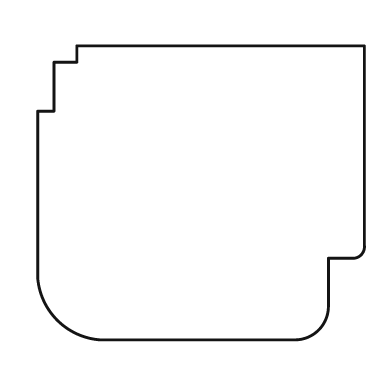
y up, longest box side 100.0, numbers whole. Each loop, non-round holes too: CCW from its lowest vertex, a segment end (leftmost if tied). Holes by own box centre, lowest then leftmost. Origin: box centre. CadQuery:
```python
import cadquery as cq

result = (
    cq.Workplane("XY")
    .moveTo(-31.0, -45.0)
    .lineTo(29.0, -45.0)
    .threePointArc((36.0, -42.0), (39.0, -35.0))
    .lineTo(39.0, -20.0)
    .lineTo(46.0, -20.0)
    .threePointArc((49.0, -19.0), (50.0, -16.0))
    .lineTo(50.0, 45.0)
    .lineTo(-38.0, 45.0)
    .lineTo(-38.0, 40.0)
    .lineTo(-45.0, 40.0)
    .lineTo(-45.0, 25.0)
    .lineTo(-50.0, 25.0)
    .lineTo(-50.0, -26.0)
    .threePointArc((-44.0, -39.0), (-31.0, -45.0))
    .close()
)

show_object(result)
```